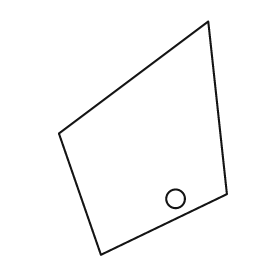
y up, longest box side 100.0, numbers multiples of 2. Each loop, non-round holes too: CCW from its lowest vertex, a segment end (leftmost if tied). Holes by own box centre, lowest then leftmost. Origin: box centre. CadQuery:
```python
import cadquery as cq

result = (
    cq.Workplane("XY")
    .moveTo(-18.0, -50.0)
    .lineTo(36.0, -24.0)
    .lineTo(28.0, 50.0)
    .lineTo(-36.0, 2.0)
    .close()
    .moveTo(14.0, -26.0)
    .circle(4.0)
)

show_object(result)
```